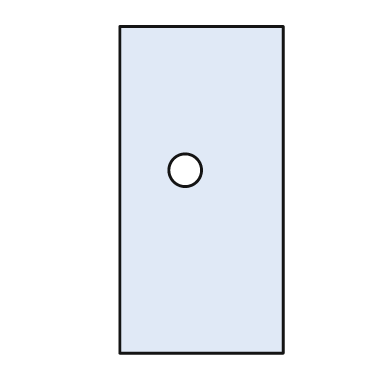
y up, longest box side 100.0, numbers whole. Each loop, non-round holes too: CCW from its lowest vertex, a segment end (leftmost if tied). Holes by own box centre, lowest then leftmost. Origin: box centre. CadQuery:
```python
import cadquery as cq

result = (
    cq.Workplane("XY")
    .moveTo(-25.0, -50.0)
    .lineTo(25.0, -50.0)
    .lineTo(25.0, 50.0)
    .lineTo(-25.0, 50.0)
    .close()
    .moveTo(-5.0, 6.0)
    .circle(5.0)
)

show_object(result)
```